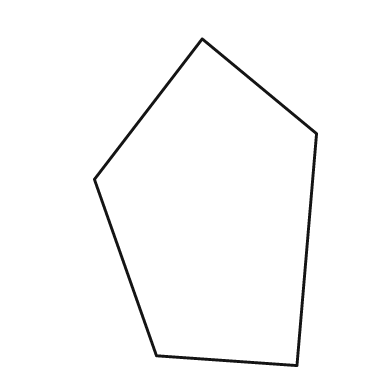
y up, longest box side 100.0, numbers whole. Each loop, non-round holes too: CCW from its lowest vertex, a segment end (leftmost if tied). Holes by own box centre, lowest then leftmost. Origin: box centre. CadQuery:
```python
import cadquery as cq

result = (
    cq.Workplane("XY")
    .moveTo(28.0, -50.0)
    .lineTo(34.0, 21.0)
    .lineTo(-1.0, 50.0)
    .lineTo(-34.0, 7.0)
    .lineTo(-15.0, -47.0)
    .close()
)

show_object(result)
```